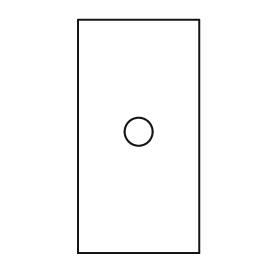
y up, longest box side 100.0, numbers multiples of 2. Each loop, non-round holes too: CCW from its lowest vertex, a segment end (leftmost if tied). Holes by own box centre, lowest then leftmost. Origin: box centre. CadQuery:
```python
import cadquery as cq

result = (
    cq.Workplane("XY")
    .moveTo(-26.0, -50.0)
    .lineTo(26.0, -50.0)
    .lineTo(26.0, 50.0)
    .lineTo(-26.0, 50.0)
    .close()
    .moveTo(0.0, 2.0)
    .circle(6.0)
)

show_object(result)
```